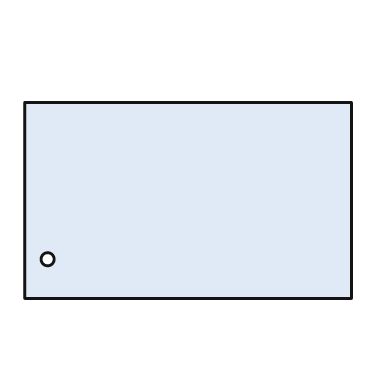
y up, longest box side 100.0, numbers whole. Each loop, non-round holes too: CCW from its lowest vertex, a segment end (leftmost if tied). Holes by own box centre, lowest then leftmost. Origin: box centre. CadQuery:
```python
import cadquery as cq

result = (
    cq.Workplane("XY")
    .moveTo(-50.0, -30.0)
    .lineTo(50.0, -30.0)
    .lineTo(50.0, 30.0)
    .lineTo(-50.0, 30.0)
    .close()
    .moveTo(-43.0, -18.0)
    .circle(2.0)
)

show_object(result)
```